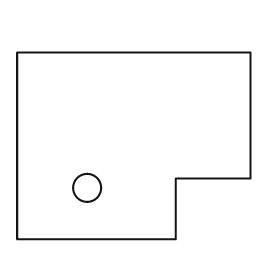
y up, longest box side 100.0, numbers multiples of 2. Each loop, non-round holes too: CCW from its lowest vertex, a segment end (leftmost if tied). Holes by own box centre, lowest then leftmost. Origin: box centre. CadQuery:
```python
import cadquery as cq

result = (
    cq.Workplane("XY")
    .moveTo(-50.0, -40.0)
    .lineTo(18.0, -40.0)
    .lineTo(18.0, -14.0)
    .lineTo(50.0, -14.0)
    .lineTo(50.0, 40.0)
    .lineTo(-50.0, 40.0)
    .close()
    .moveTo(-20.0, -18.0)
    .circle(6.0)
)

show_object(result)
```